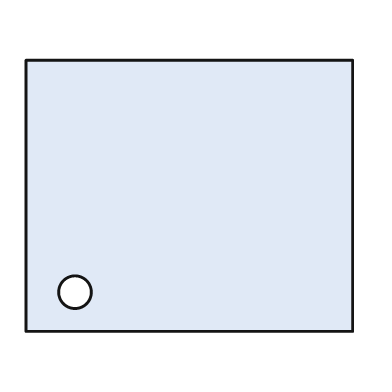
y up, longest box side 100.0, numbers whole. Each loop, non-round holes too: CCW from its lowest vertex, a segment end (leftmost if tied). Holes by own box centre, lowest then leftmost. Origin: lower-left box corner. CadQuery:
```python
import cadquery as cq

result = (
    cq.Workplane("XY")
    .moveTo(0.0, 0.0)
    .lineTo(100.0, 0.0)
    .lineTo(100.0, 83.0)
    .lineTo(0.0, 83.0)
    .close()
    .moveTo(15.0, 12.0)
    .circle(5.0)
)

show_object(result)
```